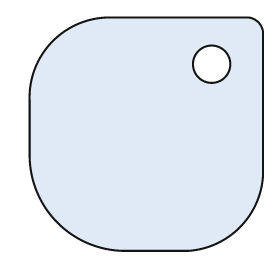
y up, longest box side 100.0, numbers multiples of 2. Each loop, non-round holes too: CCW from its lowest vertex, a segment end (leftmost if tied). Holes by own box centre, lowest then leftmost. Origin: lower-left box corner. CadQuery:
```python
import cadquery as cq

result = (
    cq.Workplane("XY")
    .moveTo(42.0, 0.0)
    .lineTo(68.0, 0.0)
    .threePointArc((90.0, 10.0), (100.0, 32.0))
    .lineTo(100.0, 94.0)
    .threePointArc((98.0, 98.0), (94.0, 100.0))
    .lineTo(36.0, 100.0)
    .threePointArc((10.0, 90.0), (0.0, 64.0))
    .lineTo(0.0, 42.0)
    .threePointArc((12.0, 12.0), (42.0, 0.0))
    .close()
    .moveTo(78.0, 80.0)
    .circle(8.0)
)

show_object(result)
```